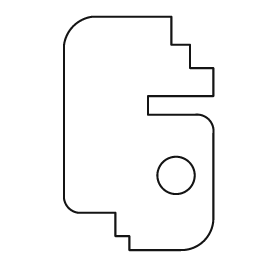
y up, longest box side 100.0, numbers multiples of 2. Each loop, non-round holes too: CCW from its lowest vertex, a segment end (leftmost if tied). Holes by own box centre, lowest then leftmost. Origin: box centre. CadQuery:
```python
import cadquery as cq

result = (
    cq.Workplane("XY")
    .moveTo(-4.0, -50.0)
    .lineTo(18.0, -50.0)
    .threePointArc((28.0, -46.0), (32.0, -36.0))
    .lineTo(32.0, 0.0)
    .threePointArc((30.0, 6.0), (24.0, 8.0))
    .lineTo(4.0, 8.0)
    .lineTo(4.0, 16.0)
    .lineTo(32.0, 16.0)
    .lineTo(32.0, 28.0)
    .lineTo(22.0, 28.0)
    .lineTo(22.0, 38.0)
    .lineTo(14.0, 38.0)
    .lineTo(14.0, 50.0)
    .lineTo(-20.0, 50.0)
    .threePointArc((-28.0, 46.0), (-32.0, 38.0))
    .lineTo(-32.0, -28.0)
    .threePointArc((-30.0, -32.0), (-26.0, -34.0))
    .lineTo(-10.0, -34.0)
    .lineTo(-10.0, -44.0)
    .lineTo(-4.0, -44.0)
    .close()
    .moveTo(16.0, -18.0)
    .circle(8.0)
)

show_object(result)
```